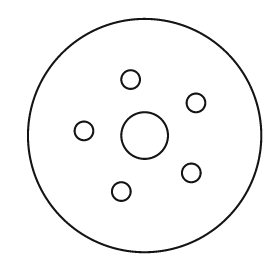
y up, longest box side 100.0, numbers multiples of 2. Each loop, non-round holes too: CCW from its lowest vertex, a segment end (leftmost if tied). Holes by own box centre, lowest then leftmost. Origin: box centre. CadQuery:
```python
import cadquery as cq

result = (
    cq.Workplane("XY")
    .moveTo(0.0, 0.0)
    .circle(50.0)
    .moveTo(-10.0, -24.0)
    .circle(4.0)
    .moveTo(20.0, -16.0)
    .circle(4.0)
    .moveTo(0.0, 0.0)
    .circle(10.0)
    .moveTo(-26.0, 2.0)
    .circle(4.0)
    .moveTo(22.0, 14.0)
    .circle(4.0)
    .moveTo(-6.0, 24.0)
    .circle(4.0)
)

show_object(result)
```